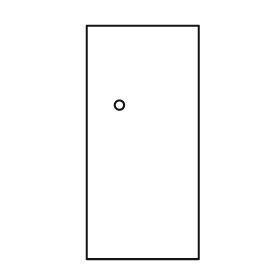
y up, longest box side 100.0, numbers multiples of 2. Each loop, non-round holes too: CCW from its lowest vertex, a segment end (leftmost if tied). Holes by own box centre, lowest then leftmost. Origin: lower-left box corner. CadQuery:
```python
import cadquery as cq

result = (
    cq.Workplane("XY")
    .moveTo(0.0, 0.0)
    .lineTo(48.0, 0.0)
    .lineTo(48.0, 100.0)
    .lineTo(0.0, 100.0)
    .close()
    .moveTo(14.0, 66.0)
    .circle(2.0)
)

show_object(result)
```